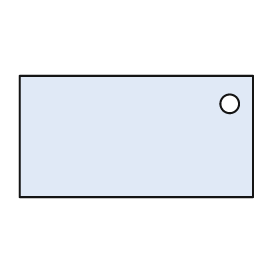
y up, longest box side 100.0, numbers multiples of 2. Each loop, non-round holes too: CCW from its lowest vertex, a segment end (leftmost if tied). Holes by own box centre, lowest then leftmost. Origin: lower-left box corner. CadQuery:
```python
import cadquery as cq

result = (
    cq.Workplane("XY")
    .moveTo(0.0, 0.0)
    .lineTo(100.0, 0.0)
    .lineTo(100.0, 52.0)
    .lineTo(0.0, 52.0)
    .close()
    .moveTo(90.0, 40.0)
    .circle(4.0)
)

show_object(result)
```